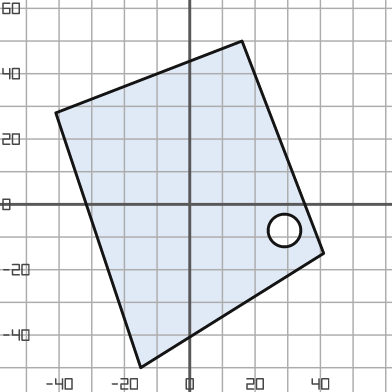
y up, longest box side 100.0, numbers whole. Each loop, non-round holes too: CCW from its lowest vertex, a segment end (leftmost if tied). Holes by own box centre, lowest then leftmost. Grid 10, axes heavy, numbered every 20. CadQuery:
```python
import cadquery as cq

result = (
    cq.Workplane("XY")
    .moveTo(-15.0, -50.0)
    .lineTo(41.0, -15.0)
    .lineTo(16.0, 50.0)
    .lineTo(-41.0, 28.0)
    .close()
    .moveTo(29.0, -8.0)
    .circle(5.0)
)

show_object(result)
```